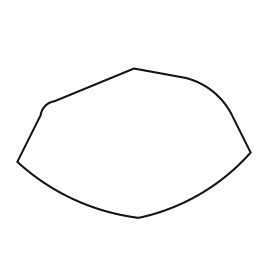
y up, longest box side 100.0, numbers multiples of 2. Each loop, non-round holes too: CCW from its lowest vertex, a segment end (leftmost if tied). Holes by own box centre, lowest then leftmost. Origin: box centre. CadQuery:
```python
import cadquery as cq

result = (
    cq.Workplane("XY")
    .moveTo(2.0, -32.0)
    .threePointArc((28.0, -22.0), (50.0, -4.0))
    .lineTo(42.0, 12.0)
    .threePointArc((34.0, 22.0), (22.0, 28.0))
    .lineTo(0.0, 32.0)
    .lineTo(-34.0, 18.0)
    .threePointArc((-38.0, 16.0), (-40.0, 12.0))
    .lineTo(-50.0, -8.0)
    .threePointArc((-26.0, -24.0), (2.0, -32.0))
    .close()
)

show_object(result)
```